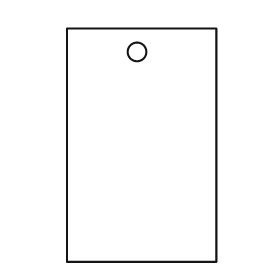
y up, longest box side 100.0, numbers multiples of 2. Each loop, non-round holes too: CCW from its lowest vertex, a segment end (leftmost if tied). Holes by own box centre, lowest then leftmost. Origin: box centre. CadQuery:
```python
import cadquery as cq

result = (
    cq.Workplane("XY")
    .moveTo(-32.0, -50.0)
    .lineTo(32.0, -50.0)
    .lineTo(32.0, 50.0)
    .lineTo(-32.0, 50.0)
    .close()
    .moveTo(-2.0, 40.0)
    .circle(4.0)
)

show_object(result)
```